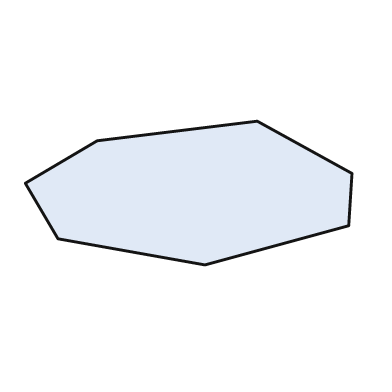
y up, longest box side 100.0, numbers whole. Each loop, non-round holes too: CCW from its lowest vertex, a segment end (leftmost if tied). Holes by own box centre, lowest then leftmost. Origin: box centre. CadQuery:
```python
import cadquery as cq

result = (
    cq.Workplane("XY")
    .moveTo(5.0, -22.0)
    .lineTo(49.0, -10.0)
    .lineTo(50.0, 6.0)
    .lineTo(21.0, 22.0)
    .lineTo(-28.0, 16.0)
    .lineTo(-50.0, 3.0)
    .lineTo(-40.0, -14.0)
    .close()
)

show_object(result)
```